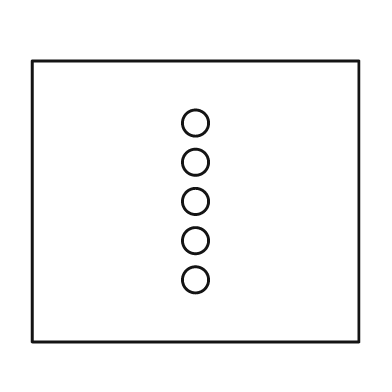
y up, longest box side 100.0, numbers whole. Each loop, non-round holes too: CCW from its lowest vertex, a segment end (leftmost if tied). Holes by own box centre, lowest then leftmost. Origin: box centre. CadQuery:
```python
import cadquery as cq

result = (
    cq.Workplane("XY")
    .moveTo(-50.0, -43.0)
    .lineTo(50.0, -43.0)
    .lineTo(50.0, 43.0)
    .lineTo(-50.0, 43.0)
    .close()
    .moveTo(0.0, -24.0)
    .circle(4.0)
    .moveTo(0.0, -12.0)
    .circle(4.0)
    .moveTo(0.0, 0.0)
    .circle(4.0)
    .moveTo(0.0, 12.0)
    .circle(4.0)
    .moveTo(0.0, 24.0)
    .circle(4.0)
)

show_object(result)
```